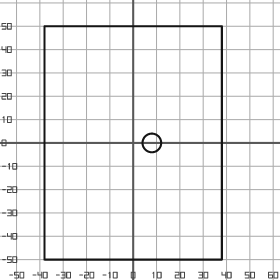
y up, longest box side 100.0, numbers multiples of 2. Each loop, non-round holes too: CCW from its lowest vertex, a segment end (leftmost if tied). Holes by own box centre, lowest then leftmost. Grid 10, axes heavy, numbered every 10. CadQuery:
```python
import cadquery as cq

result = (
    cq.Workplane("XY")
    .moveTo(-38.0, -50.0)
    .lineTo(38.0, -50.0)
    .lineTo(38.0, 50.0)
    .lineTo(-38.0, 50.0)
    .close()
    .moveTo(8.0, 0.0)
    .circle(4.0)
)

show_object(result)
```